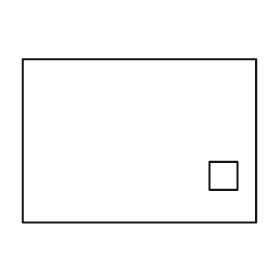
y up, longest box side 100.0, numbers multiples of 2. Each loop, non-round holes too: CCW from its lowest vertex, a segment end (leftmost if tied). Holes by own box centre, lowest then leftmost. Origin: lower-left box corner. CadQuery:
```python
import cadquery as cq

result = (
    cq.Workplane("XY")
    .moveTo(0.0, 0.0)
    .lineTo(100.0, 0.0)
    .lineTo(100.0, 70.0)
    .lineTo(0.0, 70.0)
    .close()
    .moveTo(80.0, 14.0)
    .lineTo(92.0, 14.0)
    .lineTo(92.0, 26.0)
    .lineTo(80.0, 26.0)
    .close()
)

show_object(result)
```